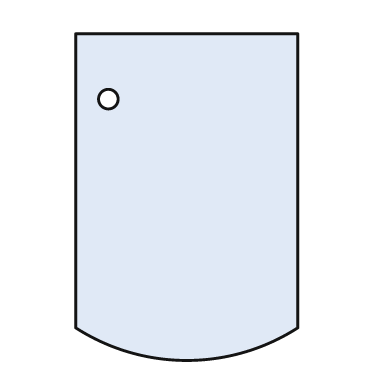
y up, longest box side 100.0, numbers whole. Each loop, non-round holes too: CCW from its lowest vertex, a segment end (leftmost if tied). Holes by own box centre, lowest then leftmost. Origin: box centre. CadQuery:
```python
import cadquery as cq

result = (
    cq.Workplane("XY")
    .moveTo(-34.0, -40.0)
    .threePointArc((0.0, -50.0), (34.0, -40.0))
    .lineTo(34.0, 50.0)
    .lineTo(-34.0, 50.0)
    .close()
    .moveTo(-24.0, 30.0)
    .circle(3.0)
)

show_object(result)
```